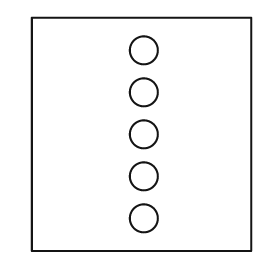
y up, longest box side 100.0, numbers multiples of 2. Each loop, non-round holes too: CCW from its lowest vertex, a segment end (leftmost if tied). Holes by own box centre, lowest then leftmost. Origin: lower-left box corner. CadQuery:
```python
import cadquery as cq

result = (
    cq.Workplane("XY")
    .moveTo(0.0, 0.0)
    .lineTo(94.0, 0.0)
    .lineTo(94.0, 100.0)
    .lineTo(0.0, 100.0)
    .close()
    .moveTo(48.0, 14.0)
    .circle(6.0)
    .moveTo(48.0, 32.0)
    .circle(6.0)
    .moveTo(48.0, 50.0)
    .circle(6.0)
    .moveTo(48.0, 68.0)
    .circle(6.0)
    .moveTo(48.0, 86.0)
    .circle(6.0)
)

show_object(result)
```